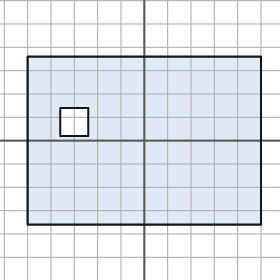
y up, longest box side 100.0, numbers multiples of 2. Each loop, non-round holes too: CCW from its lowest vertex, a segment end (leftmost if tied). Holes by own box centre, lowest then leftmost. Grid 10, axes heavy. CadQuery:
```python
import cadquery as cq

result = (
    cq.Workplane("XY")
    .moveTo(-50.0, -36.0)
    .lineTo(50.0, -36.0)
    .lineTo(50.0, 36.0)
    .lineTo(-50.0, 36.0)
    .close()
    .moveTo(-36.0, 2.0)
    .lineTo(-24.0, 2.0)
    .lineTo(-24.0, 14.0)
    .lineTo(-36.0, 14.0)
    .close()
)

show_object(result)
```